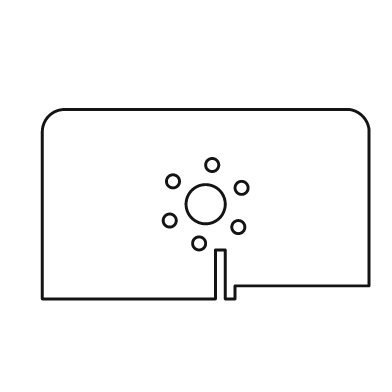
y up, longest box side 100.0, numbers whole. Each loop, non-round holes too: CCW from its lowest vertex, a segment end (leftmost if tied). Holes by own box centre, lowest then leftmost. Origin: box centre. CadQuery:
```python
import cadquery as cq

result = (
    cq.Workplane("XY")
    .moveTo(-50.0, -29.0)
    .lineTo(3.0, -29.0)
    .lineTo(3.0, -14.0)
    .lineTo(6.0, -14.0)
    .lineTo(6.0, -29.0)
    .lineTo(9.0, -29.0)
    .lineTo(9.0, -25.0)
    .lineTo(50.0, -25.0)
    .lineTo(50.0, 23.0)
    .threePointArc((48.0, 27.0), (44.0, 29.0))
    .lineTo(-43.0, 29.0)
    .threePointArc((-48.0, 27.0), (-50.0, 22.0))
    .close()
    .moveTo(-2.0, -12.0)
    .circle(2.0)
    .moveTo(10.0, -7.0)
    .circle(2.0)
    .moveTo(-11.0, -5.0)
    .circle(2.0)
    .moveTo(0.0, 0.0)
    .circle(6.0)
    .moveTo(11.0, 5.0)
    .circle(2.0)
    .moveTo(-10.0, 7.0)
    .circle(2.0)
    .moveTo(2.0, 12.0)
    .circle(2.0)
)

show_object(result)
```